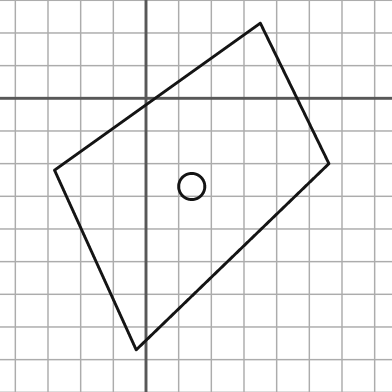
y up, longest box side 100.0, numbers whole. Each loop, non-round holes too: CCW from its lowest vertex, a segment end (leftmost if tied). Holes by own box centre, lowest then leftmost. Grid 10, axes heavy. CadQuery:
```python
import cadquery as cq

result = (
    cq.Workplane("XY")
    .moveTo(-3.0, -77.0)
    .lineTo(56.0, -20.0)
    .lineTo(35.0, 23.0)
    .lineTo(-28.0, -22.0)
    .close()
    .moveTo(14.0, -27.0)
    .circle(4.0)
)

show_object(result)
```